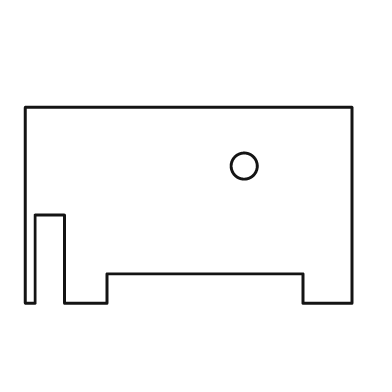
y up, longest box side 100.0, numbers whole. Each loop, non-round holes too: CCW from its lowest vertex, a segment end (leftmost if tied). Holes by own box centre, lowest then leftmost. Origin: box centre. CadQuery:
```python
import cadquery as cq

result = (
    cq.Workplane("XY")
    .moveTo(-50.0, -30.0)
    .lineTo(-47.0, -30.0)
    .lineTo(-47.0, -3.0)
    .lineTo(-38.0, -3.0)
    .lineTo(-38.0, -30.0)
    .lineTo(-25.0, -30.0)
    .lineTo(-25.0, -21.0)
    .lineTo(35.0, -21.0)
    .lineTo(35.0, -30.0)
    .lineTo(50.0, -30.0)
    .lineTo(50.0, 30.0)
    .lineTo(-50.0, 30.0)
    .close()
    .moveTo(17.0, 12.0)
    .circle(4.0)
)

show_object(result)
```